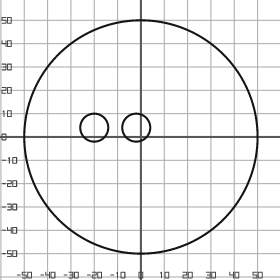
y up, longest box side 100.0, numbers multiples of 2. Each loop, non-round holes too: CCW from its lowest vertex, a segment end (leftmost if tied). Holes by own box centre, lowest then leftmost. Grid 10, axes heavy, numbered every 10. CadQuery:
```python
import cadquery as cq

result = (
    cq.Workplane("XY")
    .moveTo(0.0, 0.0)
    .circle(50.0)
    .moveTo(-20.0, 4.0)
    .circle(6.0)
    .moveTo(-2.0, 4.0)
    .circle(6.0)
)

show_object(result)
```